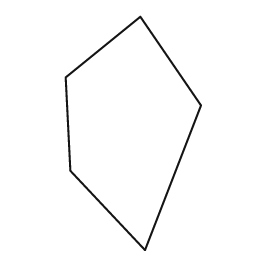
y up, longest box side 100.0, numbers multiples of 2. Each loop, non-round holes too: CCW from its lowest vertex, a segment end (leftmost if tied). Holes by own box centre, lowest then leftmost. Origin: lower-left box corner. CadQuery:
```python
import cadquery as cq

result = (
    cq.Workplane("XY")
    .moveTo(34.0, 0.0)
    .lineTo(58.0, 62.0)
    .lineTo(32.0, 100.0)
    .lineTo(0.0, 74.0)
    .lineTo(2.0, 34.0)
    .close()
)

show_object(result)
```